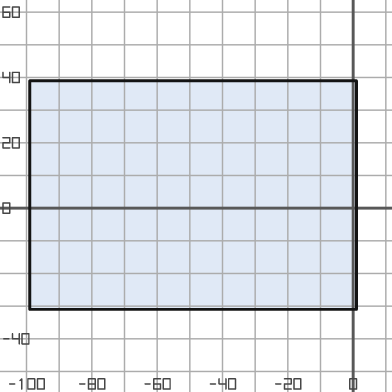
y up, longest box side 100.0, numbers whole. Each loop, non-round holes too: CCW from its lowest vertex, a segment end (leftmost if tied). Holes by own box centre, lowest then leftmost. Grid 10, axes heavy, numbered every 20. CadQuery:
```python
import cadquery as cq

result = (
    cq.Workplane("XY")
    .moveTo(-99.0, -31.0)
    .lineTo(1.0, -31.0)
    .lineTo(1.0, 39.0)
    .lineTo(-99.0, 39.0)
    .close()
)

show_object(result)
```